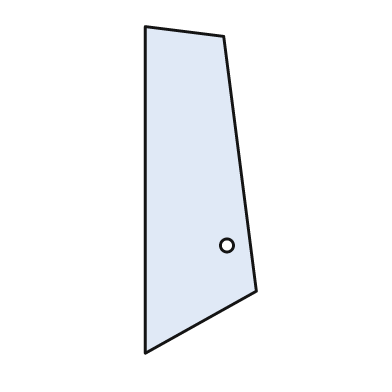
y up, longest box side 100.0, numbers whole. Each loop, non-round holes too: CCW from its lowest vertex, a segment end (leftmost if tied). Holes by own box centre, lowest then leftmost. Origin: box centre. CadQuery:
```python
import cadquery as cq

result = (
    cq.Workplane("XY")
    .moveTo(-17.0, -50.0)
    .lineTo(17.0, -31.0)
    .lineTo(7.0, 47.0)
    .lineTo(-17.0, 50.0)
    .close()
    .moveTo(8.0, -17.0)
    .circle(2.0)
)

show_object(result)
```